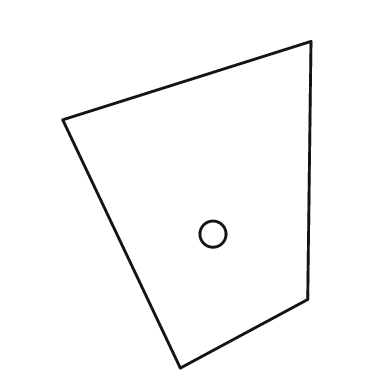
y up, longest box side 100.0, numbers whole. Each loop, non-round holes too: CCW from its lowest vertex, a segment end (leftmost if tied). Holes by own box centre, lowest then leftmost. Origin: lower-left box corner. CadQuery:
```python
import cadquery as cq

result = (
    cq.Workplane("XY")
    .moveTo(36.0, 0.0)
    .lineTo(75.0, 21.0)
    .lineTo(76.0, 100.0)
    .lineTo(0.0, 76.0)
    .close()
    .moveTo(46.0, 41.0)
    .circle(4.0)
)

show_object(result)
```